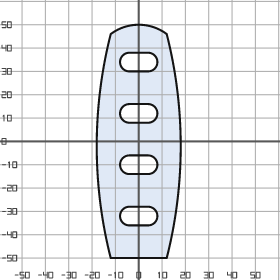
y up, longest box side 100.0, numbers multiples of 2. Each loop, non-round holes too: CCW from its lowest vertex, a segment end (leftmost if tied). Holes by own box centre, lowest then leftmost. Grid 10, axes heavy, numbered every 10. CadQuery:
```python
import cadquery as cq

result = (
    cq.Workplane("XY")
    .moveTo(-12.0, -50.0)
    .lineTo(12.0, -50.0)
    .threePointArc((18.0, -2.0), (12.0, 46.0))
    .threePointArc((0.0, 50.0), (-12.0, 46.0))
    .threePointArc((-18.0, -2.0), (-12.0, -50.0))
    .close()
    .moveTo(-4.0, -36.0)
    .lineTo(4.0, -36.0)
    .threePointArc((8.0, -32.0), (4.0, -28.0))
    .lineTo(-4.0, -28.0)
    .threePointArc((-8.0, -32.0), (-4.0, -36.0))
    .close()
    .moveTo(-4.0, -14.0)
    .lineTo(4.0, -14.0)
    .threePointArc((8.0, -10.0), (4.0, -6.0))
    .lineTo(-4.0, -6.0)
    .threePointArc((-8.0, -10.0), (-4.0, -14.0))
    .close()
    .moveTo(-4.0, 8.0)
    .lineTo(4.0, 8.0)
    .threePointArc((8.0, 12.0), (4.0, 16.0))
    .lineTo(-4.0, 16.0)
    .threePointArc((-8.0, 12.0), (-4.0, 8.0))
    .close()
    .moveTo(-4.0, 30.0)
    .lineTo(4.0, 30.0)
    .threePointArc((8.0, 34.0), (4.0, 38.0))
    .lineTo(-4.0, 38.0)
    .threePointArc((-8.0, 34.0), (-4.0, 30.0))
    .close()
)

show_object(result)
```